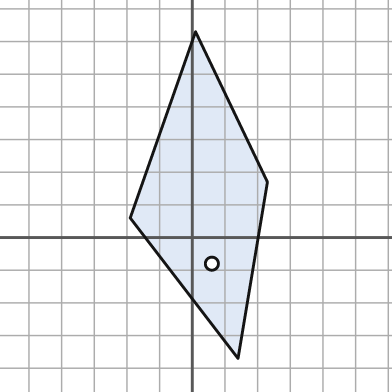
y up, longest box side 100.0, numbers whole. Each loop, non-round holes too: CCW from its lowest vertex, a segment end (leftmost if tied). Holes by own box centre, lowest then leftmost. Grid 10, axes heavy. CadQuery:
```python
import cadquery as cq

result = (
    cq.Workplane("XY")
    .moveTo(14.0, -37.0)
    .lineTo(23.0, 17.0)
    .lineTo(1.0, 63.0)
    .lineTo(-19.0, 6.0)
    .close()
    .moveTo(6.0, -8.0)
    .circle(2.0)
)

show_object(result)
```